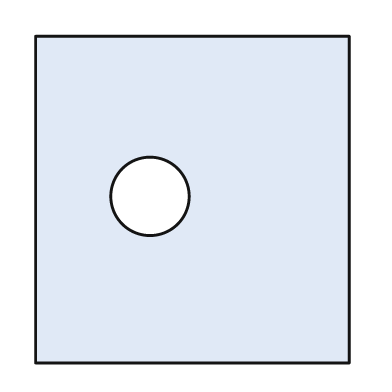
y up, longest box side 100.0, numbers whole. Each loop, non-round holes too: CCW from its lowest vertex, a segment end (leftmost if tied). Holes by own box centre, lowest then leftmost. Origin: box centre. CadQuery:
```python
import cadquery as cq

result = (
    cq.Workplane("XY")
    .moveTo(-48.0, -50.0)
    .lineTo(48.0, -50.0)
    .lineTo(48.0, 50.0)
    .lineTo(-48.0, 50.0)
    .close()
    .moveTo(-13.0, 1.0)
    .circle(12.0)
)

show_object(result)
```